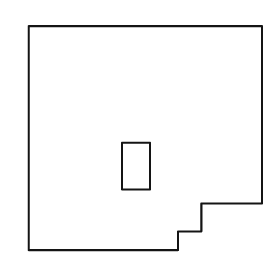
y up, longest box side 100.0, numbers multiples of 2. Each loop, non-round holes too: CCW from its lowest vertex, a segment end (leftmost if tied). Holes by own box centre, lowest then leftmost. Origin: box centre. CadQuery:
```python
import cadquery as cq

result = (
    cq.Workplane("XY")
    .moveTo(-50.0, -48.0)
    .lineTo(14.0, -48.0)
    .lineTo(14.0, -40.0)
    .lineTo(24.0, -40.0)
    .lineTo(24.0, -28.0)
    .lineTo(50.0, -28.0)
    .lineTo(50.0, 48.0)
    .lineTo(-50.0, 48.0)
    .close()
    .moveTo(-10.0, -22.0)
    .lineTo(2.0, -22.0)
    .lineTo(2.0, -2.0)
    .lineTo(-10.0, -2.0)
    .close()
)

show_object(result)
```